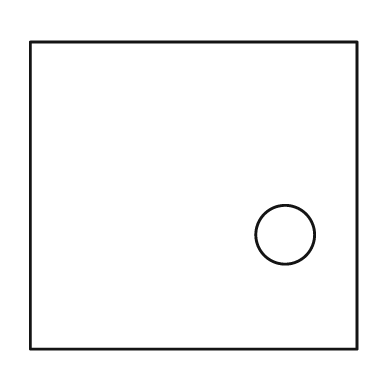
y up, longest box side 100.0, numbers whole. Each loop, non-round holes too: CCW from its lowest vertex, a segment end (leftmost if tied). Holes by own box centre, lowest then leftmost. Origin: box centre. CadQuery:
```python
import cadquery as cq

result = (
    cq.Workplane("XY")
    .moveTo(-50.0, -47.0)
    .lineTo(50.0, -47.0)
    .lineTo(50.0, 47.0)
    .lineTo(-50.0, 47.0)
    .close()
    .moveTo(28.0, -12.0)
    .circle(9.0)
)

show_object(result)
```